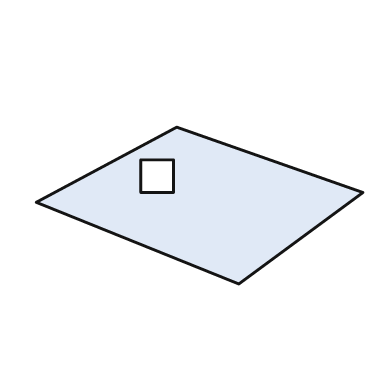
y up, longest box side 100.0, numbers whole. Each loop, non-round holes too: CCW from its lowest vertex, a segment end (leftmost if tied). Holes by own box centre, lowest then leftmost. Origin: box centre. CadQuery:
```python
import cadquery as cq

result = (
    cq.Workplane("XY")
    .moveTo(12.0, -24.0)
    .lineTo(50.0, 4.0)
    .lineTo(-7.0, 24.0)
    .lineTo(-50.0, 1.0)
    .close()
    .moveTo(-18.0, 4.0)
    .lineTo(-8.0, 4.0)
    .lineTo(-8.0, 14.0)
    .lineTo(-18.0, 14.0)
    .close()
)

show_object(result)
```